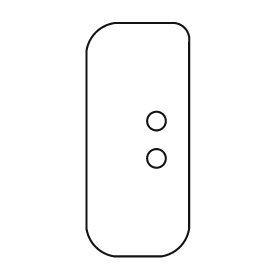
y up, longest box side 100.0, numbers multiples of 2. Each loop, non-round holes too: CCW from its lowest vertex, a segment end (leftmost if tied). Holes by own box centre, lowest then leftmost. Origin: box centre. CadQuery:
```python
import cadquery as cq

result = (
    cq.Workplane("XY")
    .moveTo(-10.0, -50.0)
    .lineTo(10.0, -50.0)
    .threePointArc((18.0, -46.0), (22.0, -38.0))
    .lineTo(22.0, 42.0)
    .threePointArc((20.0, 48.0), (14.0, 50.0))
    .lineTo(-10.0, 50.0)
    .threePointArc((-18.0, 46.0), (-22.0, 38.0))
    .lineTo(-22.0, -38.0)
    .threePointArc((-18.0, -46.0), (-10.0, -50.0))
    .close()
    .moveTo(8.0, -8.0)
    .circle(4.0)
    .moveTo(8.0, 8.0)
    .circle(4.0)
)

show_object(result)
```